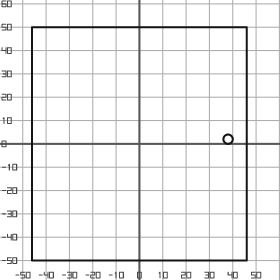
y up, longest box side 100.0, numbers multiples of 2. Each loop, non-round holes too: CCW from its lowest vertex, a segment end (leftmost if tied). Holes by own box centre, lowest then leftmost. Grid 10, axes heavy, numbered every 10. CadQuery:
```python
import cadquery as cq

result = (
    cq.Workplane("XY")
    .moveTo(-46.0, -50.0)
    .lineTo(46.0, -50.0)
    .lineTo(46.0, 50.0)
    .lineTo(-46.0, 50.0)
    .close()
    .moveTo(38.0, 2.0)
    .circle(2.0)
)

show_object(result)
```